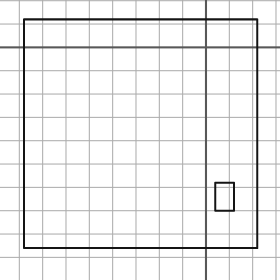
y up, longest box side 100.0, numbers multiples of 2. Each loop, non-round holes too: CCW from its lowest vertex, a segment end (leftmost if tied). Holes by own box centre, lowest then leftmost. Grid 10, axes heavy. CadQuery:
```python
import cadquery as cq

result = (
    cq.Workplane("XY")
    .moveTo(-78.0, -86.0)
    .lineTo(22.0, -86.0)
    .lineTo(22.0, 12.0)
    .lineTo(-78.0, 12.0)
    .close()
    .moveTo(4.0, -70.0)
    .lineTo(12.0, -70.0)
    .lineTo(12.0, -58.0)
    .lineTo(4.0, -58.0)
    .close()
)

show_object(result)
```